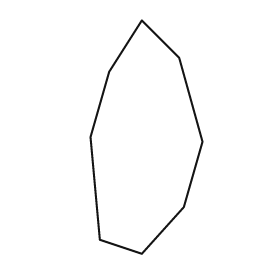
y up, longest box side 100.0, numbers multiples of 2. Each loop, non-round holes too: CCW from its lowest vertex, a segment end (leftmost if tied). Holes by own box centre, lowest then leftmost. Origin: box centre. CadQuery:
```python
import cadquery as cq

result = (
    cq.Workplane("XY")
    .moveTo(-2.0, -50.0)
    .lineTo(16.0, -30.0)
    .lineTo(24.0, -2.0)
    .lineTo(14.0, 34.0)
    .lineTo(-2.0, 50.0)
    .lineTo(-16.0, 28.0)
    .lineTo(-24.0, 0.0)
    .lineTo(-20.0, -44.0)
    .close()
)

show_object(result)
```